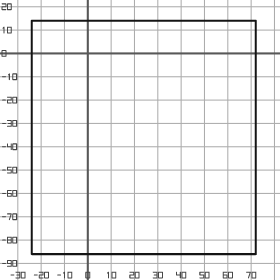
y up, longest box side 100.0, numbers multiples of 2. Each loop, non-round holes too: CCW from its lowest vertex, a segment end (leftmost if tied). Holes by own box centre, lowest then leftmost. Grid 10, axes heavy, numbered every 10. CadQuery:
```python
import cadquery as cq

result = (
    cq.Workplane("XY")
    .moveTo(-24.0, -86.0)
    .lineTo(72.0, -86.0)
    .lineTo(72.0, 14.0)
    .lineTo(-24.0, 14.0)
    .close()
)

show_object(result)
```